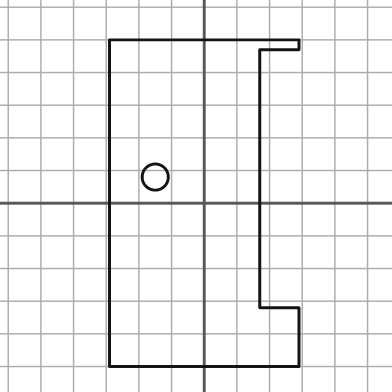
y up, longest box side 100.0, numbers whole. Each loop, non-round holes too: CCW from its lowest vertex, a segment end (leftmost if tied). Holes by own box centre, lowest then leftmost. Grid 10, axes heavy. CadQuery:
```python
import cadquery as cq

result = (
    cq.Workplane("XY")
    .moveTo(-29.0, -50.0)
    .lineTo(29.0, -50.0)
    .lineTo(29.0, -32.0)
    .lineTo(17.0, -32.0)
    .lineTo(17.0, 47.0)
    .lineTo(29.0, 47.0)
    .lineTo(29.0, 50.0)
    .lineTo(-29.0, 50.0)
    .close()
    .moveTo(-15.0, 8.0)
    .circle(4.0)
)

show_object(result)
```